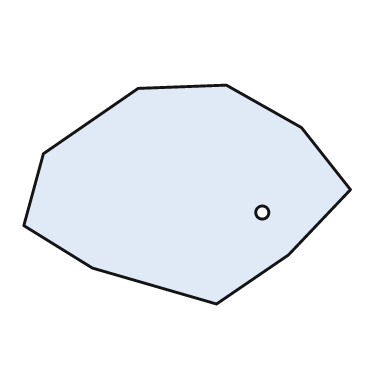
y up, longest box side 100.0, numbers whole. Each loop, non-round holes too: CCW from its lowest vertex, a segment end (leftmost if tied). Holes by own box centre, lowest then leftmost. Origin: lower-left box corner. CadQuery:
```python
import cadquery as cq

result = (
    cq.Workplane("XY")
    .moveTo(59.0, 0.0)
    .lineTo(81.0, 15.0)
    .lineTo(100.0, 35.0)
    .lineTo(85.0, 54.0)
    .lineTo(62.0, 67.0)
    .lineTo(35.0, 66.0)
    .lineTo(6.0, 46.0)
    .lineTo(0.0, 24.0)
    .lineTo(21.0, 11.0)
    .close()
    .moveTo(73.0, 28.0)
    .circle(2.0)
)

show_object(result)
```